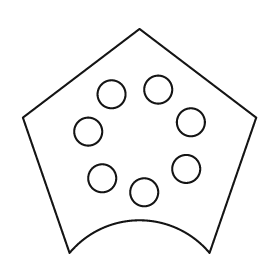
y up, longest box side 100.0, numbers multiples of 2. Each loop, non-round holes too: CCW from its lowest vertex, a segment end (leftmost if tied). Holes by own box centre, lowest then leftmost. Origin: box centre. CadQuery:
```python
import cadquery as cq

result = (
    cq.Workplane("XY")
    .moveTo(-30.0, -48.0)
    .threePointArc((0.0, -34.0), (30.0, -48.0))
    .lineTo(50.0, 10.0)
    .lineTo(0.0, 48.0)
    .lineTo(-50.0, 10.0)
    .close()
    .moveTo(2.0, -22.0)
    .circle(6.0)
    .moveTo(-16.0, -16.0)
    .circle(6.0)
    .moveTo(20.0, -12.0)
    .circle(6.0)
    .moveTo(-22.0, 4.0)
    .circle(6.0)
    .moveTo(22.0, 8.0)
    .circle(6.0)
    .moveTo(-12.0, 20.0)
    .circle(6.0)
    .moveTo(8.0, 22.0)
    .circle(6.0)
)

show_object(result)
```